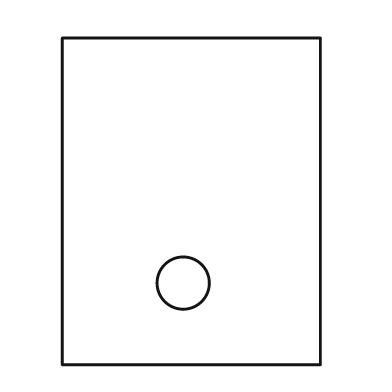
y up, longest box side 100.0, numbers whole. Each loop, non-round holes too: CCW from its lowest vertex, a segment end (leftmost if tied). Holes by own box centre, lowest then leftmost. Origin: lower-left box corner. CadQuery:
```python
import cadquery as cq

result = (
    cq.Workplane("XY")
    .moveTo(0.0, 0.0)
    .lineTo(79.0, 0.0)
    .lineTo(79.0, 100.0)
    .lineTo(0.0, 100.0)
    .close()
    .moveTo(37.0, 25.0)
    .circle(8.0)
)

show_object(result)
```